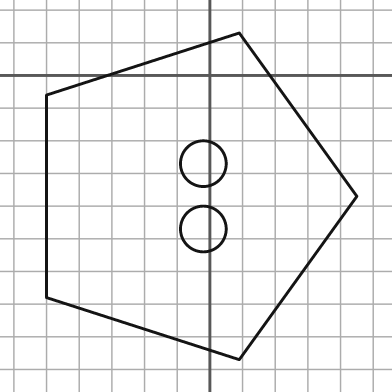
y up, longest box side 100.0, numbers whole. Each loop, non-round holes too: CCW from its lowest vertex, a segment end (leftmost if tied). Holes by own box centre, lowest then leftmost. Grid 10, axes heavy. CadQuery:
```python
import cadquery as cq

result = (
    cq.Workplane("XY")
    .moveTo(9.0, -87.0)
    .lineTo(45.0, -37.0)
    .lineTo(9.0, 13.0)
    .lineTo(-50.0, -6.0)
    .lineTo(-50.0, -68.0)
    .close()
    .moveTo(-2.0, -47.0)
    .circle(7.0)
    .moveTo(-2.0, -27.0)
    .circle(7.0)
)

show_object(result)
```